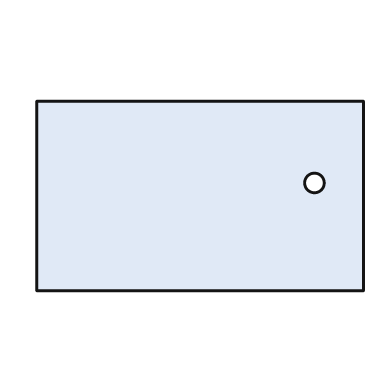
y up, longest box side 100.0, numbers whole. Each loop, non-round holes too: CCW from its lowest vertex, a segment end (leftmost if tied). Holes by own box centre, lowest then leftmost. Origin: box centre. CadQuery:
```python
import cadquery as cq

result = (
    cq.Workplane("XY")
    .moveTo(-50.0, -29.0)
    .lineTo(50.0, -29.0)
    .lineTo(50.0, 29.0)
    .lineTo(-50.0, 29.0)
    .close()
    .moveTo(35.0, 4.0)
    .circle(3.0)
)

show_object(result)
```